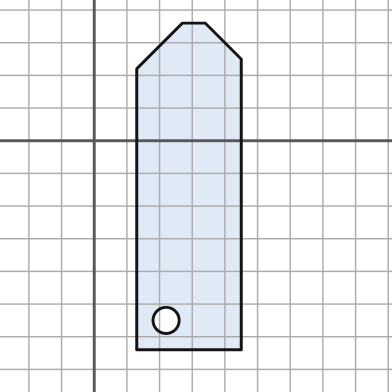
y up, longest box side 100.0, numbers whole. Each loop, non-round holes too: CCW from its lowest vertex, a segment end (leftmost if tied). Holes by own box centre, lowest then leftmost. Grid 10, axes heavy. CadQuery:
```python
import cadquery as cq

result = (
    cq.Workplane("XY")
    .moveTo(13.0, -64.0)
    .lineTo(45.0, -64.0)
    .lineTo(45.0, 25.0)
    .lineTo(34.0, 36.0)
    .lineTo(27.0, 36.0)
    .lineTo(13.0, 22.0)
    .close()
    .moveTo(22.0, -55.0)
    .circle(4.0)
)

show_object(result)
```